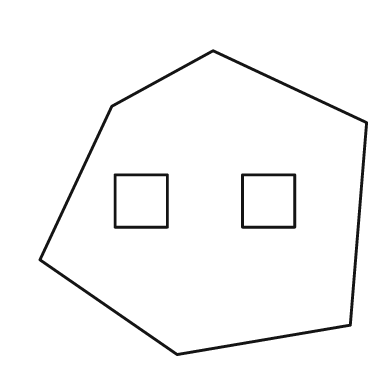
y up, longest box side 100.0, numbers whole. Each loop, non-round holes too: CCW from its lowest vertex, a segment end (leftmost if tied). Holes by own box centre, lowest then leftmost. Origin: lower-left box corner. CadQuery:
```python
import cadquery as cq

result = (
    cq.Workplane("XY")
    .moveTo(42.0, 0.0)
    .lineTo(95.0, 9.0)
    .lineTo(100.0, 71.0)
    .lineTo(53.0, 93.0)
    .lineTo(22.0, 76.0)
    .lineTo(0.0, 29.0)
    .close()
    .moveTo(23.0, 39.0)
    .lineTo(39.0, 39.0)
    .lineTo(39.0, 55.0)
    .lineTo(23.0, 55.0)
    .close()
    .moveTo(62.0, 39.0)
    .lineTo(78.0, 39.0)
    .lineTo(78.0, 55.0)
    .lineTo(62.0, 55.0)
    .close()
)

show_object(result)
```